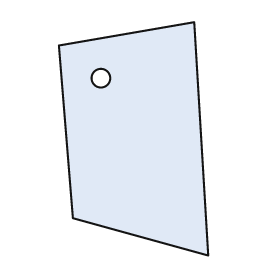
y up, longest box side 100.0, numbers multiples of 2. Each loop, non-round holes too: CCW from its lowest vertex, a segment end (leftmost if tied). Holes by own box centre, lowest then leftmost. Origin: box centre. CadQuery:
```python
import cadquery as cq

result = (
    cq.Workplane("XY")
    .moveTo(32.0, -50.0)
    .lineTo(26.0, 50.0)
    .lineTo(-32.0, 40.0)
    .lineTo(-26.0, -34.0)
    .close()
    .moveTo(-14.0, 26.0)
    .circle(4.0)
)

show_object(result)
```